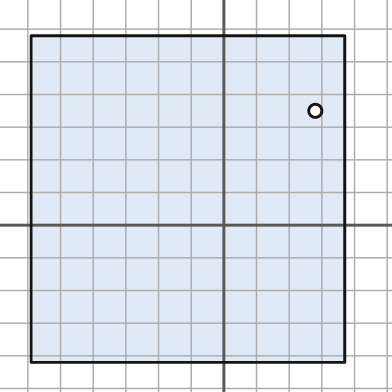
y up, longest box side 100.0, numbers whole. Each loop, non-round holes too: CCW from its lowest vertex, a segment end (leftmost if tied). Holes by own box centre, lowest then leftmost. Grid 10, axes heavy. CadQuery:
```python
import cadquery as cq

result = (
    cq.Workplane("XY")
    .moveTo(-59.0, -42.0)
    .lineTo(37.0, -42.0)
    .lineTo(37.0, 58.0)
    .lineTo(-59.0, 58.0)
    .close()
    .moveTo(28.0, 35.0)
    .circle(2.0)
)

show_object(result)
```